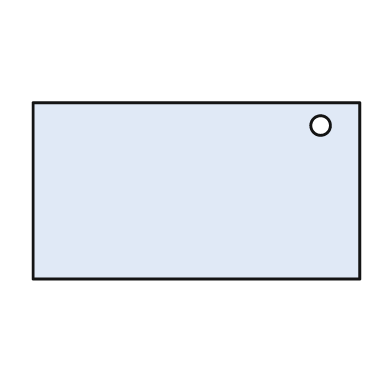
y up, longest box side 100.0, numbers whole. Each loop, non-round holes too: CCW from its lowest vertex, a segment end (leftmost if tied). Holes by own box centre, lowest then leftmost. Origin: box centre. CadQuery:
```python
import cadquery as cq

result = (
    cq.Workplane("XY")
    .moveTo(-50.0, -27.0)
    .lineTo(50.0, -27.0)
    .lineTo(50.0, 27.0)
    .lineTo(-50.0, 27.0)
    .close()
    .moveTo(38.0, 20.0)
    .circle(3.0)
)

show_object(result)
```